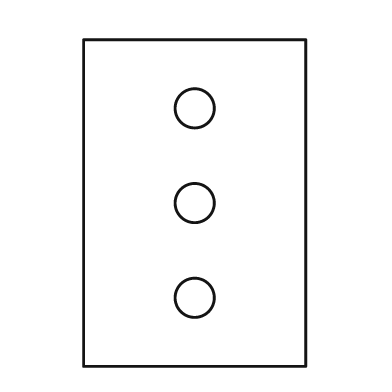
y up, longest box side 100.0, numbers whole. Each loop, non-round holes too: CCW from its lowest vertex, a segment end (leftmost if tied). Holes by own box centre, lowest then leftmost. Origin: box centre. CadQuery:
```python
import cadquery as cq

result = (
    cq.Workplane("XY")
    .moveTo(-34.0, -50.0)
    .lineTo(34.0, -50.0)
    .lineTo(34.0, 50.0)
    .lineTo(-34.0, 50.0)
    .close()
    .moveTo(0.0, -29.0)
    .circle(6.0)
    .moveTo(0.0, 0.0)
    .circle(6.0)
    .moveTo(0.0, 29.0)
    .circle(6.0)
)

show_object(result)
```